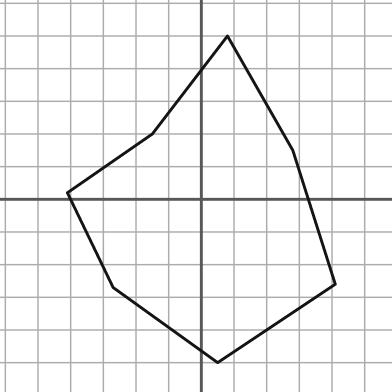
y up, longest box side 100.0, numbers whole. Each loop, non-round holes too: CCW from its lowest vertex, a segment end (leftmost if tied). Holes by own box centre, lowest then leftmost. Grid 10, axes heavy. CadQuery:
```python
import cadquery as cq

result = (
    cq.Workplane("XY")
    .moveTo(5.0, -50.0)
    .lineTo(41.0, -26.0)
    .lineTo(28.0, 15.0)
    .lineTo(8.0, 50.0)
    .lineTo(-15.0, 20.0)
    .lineTo(-41.0, 2.0)
    .lineTo(-27.0, -27.0)
    .close()
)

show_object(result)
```